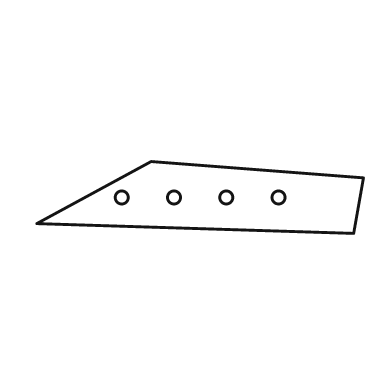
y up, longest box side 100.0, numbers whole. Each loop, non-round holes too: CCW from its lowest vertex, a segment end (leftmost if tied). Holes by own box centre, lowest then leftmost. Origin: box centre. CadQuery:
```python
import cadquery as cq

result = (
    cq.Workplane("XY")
    .moveTo(47.0, -11.0)
    .lineTo(50.0, 6.0)
    .lineTo(-15.0, 11.0)
    .lineTo(-50.0, -8.0)
    .close()
    .moveTo(-24.0, 0.0)
    .circle(2.0)
    .moveTo(-8.0, 0.0)
    .circle(2.0)
    .moveTo(8.0, 0.0)
    .circle(2.0)
    .moveTo(24.0, 0.0)
    .circle(2.0)
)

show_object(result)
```